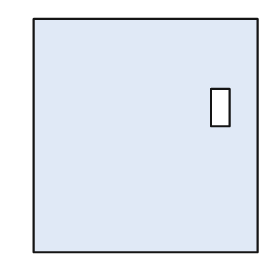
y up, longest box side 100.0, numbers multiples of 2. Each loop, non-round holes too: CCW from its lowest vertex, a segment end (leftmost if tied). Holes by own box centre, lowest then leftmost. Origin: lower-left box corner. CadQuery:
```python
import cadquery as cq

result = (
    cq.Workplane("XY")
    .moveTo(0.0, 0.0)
    .lineTo(96.0, 0.0)
    .lineTo(96.0, 100.0)
    .lineTo(0.0, 100.0)
    .close()
    .moveTo(76.0, 54.0)
    .lineTo(84.0, 54.0)
    .lineTo(84.0, 70.0)
    .lineTo(76.0, 70.0)
    .close()
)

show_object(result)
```